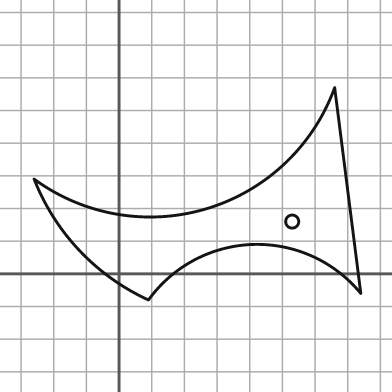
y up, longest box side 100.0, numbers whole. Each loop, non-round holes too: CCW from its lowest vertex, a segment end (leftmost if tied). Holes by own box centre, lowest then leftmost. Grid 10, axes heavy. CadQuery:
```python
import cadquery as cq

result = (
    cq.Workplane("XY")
    .moveTo(9.0, -8.0)
    .threePointArc((41.0, 9.0), (74.0, -6.0))
    .lineTo(66.0, 57.0)
    .threePointArc((27.0, 20.0), (-26.0, 29.0))
    .threePointArc((-12.0, 7.0), (9.0, -8.0))
    .close()
    .moveTo(53.0, 16.0)
    .circle(2.0)
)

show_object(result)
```